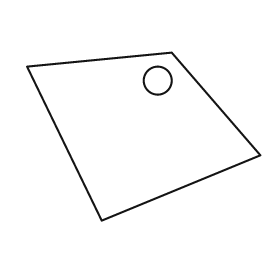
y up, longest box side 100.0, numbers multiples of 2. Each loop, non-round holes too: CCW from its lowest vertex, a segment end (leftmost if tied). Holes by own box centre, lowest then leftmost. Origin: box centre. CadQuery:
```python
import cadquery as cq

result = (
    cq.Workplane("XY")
    .moveTo(-18.0, -36.0)
    .lineTo(50.0, -8.0)
    .lineTo(12.0, 36.0)
    .lineTo(-50.0, 30.0)
    .close()
    .moveTo(6.0, 24.0)
    .circle(6.0)
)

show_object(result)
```